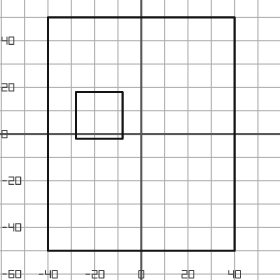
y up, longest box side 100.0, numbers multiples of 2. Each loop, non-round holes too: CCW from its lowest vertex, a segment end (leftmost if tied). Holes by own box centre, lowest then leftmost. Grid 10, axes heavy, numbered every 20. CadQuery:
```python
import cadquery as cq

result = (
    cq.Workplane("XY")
    .moveTo(-40.0, -50.0)
    .lineTo(40.0, -50.0)
    .lineTo(40.0, 50.0)
    .lineTo(-40.0, 50.0)
    .close()
    .moveTo(-28.0, -2.0)
    .lineTo(-8.0, -2.0)
    .lineTo(-8.0, 18.0)
    .lineTo(-28.0, 18.0)
    .close()
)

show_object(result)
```